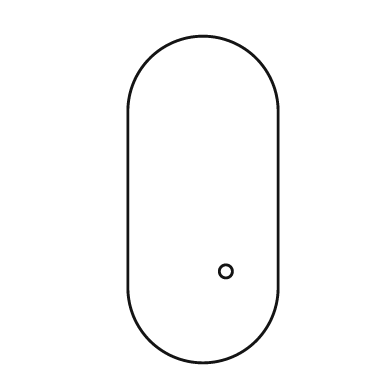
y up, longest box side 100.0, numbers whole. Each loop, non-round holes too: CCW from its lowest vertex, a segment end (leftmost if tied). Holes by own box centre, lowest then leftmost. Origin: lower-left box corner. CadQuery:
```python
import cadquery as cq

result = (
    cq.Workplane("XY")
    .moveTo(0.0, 23.0)
    .threePointArc((23.0, 0.0), (46.0, 23.0))
    .lineTo(46.0, 77.0)
    .threePointArc((23.0, 100.0), (0.0, 77.0))
    .close()
    .moveTo(30.0, 28.0)
    .circle(2.0)
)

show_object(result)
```